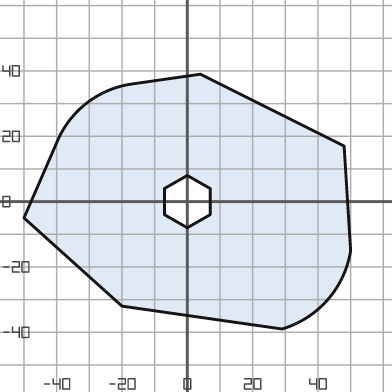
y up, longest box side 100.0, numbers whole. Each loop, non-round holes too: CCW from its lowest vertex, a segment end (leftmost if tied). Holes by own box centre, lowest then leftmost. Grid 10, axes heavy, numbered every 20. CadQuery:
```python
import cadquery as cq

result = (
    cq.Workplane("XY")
    .moveTo(29.0, -39.0)
    .threePointArc((43.0, -30.0), (50.0, -15.0))
    .lineTo(48.0, 17.0)
    .lineTo(4.0, 39.0)
    .lineTo(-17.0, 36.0)
    .threePointArc((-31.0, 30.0), (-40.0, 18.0))
    .lineTo(-50.0, -5.0)
    .lineTo(-20.0, -32.0)
    .close()
    .moveTo(0.0, -8.0)
    .lineTo(7.0, -4.0)
    .lineTo(7.0, 4.0)
    .lineTo(0.0, 8.0)
    .lineTo(-7.0, 4.0)
    .lineTo(-7.0, -4.0)
    .close()
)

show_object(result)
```